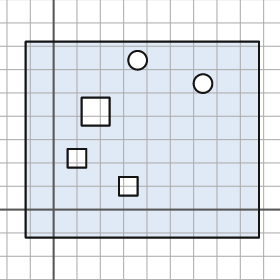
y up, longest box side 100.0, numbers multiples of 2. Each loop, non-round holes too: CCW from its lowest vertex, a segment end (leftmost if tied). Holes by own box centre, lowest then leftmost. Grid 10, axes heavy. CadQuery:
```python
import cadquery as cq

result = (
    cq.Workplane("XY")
    .moveTo(-12.0, -12.0)
    .lineTo(88.0, -12.0)
    .lineTo(88.0, 72.0)
    .lineTo(-12.0, 72.0)
    .close()
    .moveTo(28.0, 6.0)
    .lineTo(36.0, 6.0)
    .lineTo(36.0, 14.0)
    .lineTo(28.0, 14.0)
    .close()
    .moveTo(6.0, 18.0)
    .lineTo(14.0, 18.0)
    .lineTo(14.0, 26.0)
    .lineTo(6.0, 26.0)
    .close()
    .moveTo(12.0, 36.0)
    .lineTo(24.0, 36.0)
    .lineTo(24.0, 48.0)
    .lineTo(12.0, 48.0)
    .close()
    .moveTo(64.0, 54.0)
    .circle(4.0)
    .moveTo(36.0, 64.0)
    .circle(4.0)
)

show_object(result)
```